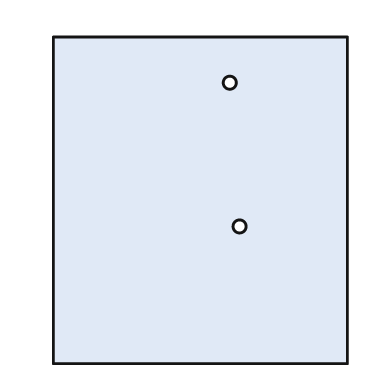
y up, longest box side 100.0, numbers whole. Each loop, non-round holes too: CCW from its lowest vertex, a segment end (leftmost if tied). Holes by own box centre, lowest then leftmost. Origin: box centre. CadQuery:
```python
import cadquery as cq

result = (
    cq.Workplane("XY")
    .moveTo(-45.0, -50.0)
    .lineTo(45.0, -50.0)
    .lineTo(45.0, 50.0)
    .lineTo(-45.0, 50.0)
    .close()
    .moveTo(12.0, -8.0)
    .circle(2.0)
    .moveTo(9.0, 36.0)
    .circle(2.0)
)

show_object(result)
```